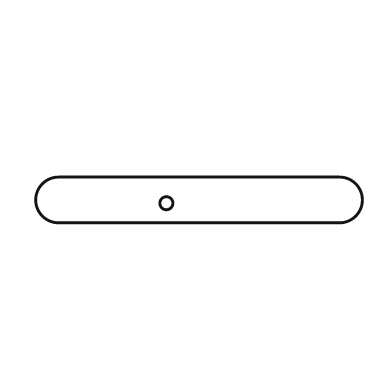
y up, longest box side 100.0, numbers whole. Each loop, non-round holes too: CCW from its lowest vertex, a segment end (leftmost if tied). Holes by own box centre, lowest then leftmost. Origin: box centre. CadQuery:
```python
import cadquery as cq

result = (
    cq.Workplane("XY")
    .moveTo(-43.0, -7.0)
    .lineTo(43.0, -7.0)
    .threePointArc((50.0, 0.0), (43.0, 7.0))
    .lineTo(-43.0, 7.0)
    .threePointArc((-50.0, 0.0), (-43.0, -7.0))
    .close()
    .moveTo(-10.0, -1.0)
    .circle(2.0)
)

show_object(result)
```